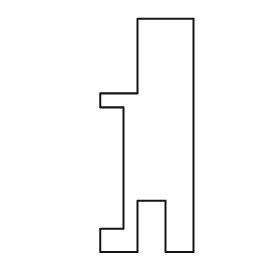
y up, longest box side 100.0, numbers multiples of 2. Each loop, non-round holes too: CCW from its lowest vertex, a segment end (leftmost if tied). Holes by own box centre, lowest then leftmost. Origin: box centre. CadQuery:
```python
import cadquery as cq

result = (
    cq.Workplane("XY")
    .moveTo(-20.0, -50.0)
    .lineTo(-4.0, -50.0)
    .lineTo(-4.0, -28.0)
    .lineTo(8.0, -28.0)
    .lineTo(8.0, -50.0)
    .lineTo(20.0, -50.0)
    .lineTo(20.0, 50.0)
    .lineTo(-4.0, 50.0)
    .lineTo(-4.0, 18.0)
    .lineTo(-20.0, 18.0)
    .lineTo(-20.0, 12.0)
    .lineTo(-10.0, 12.0)
    .lineTo(-10.0, -40.0)
    .lineTo(-20.0, -40.0)
    .close()
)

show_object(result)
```